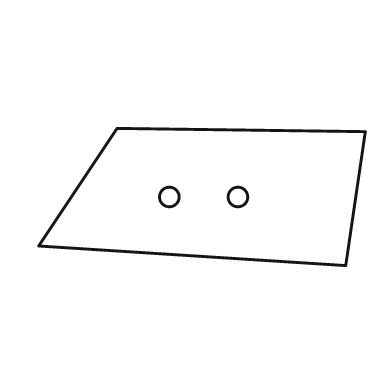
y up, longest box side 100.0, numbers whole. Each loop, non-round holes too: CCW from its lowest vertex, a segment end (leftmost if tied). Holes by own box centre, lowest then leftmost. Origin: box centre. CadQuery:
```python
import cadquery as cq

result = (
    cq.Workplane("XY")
    .moveTo(44.0, -21.0)
    .lineTo(50.0, 20.0)
    .lineTo(-26.0, 21.0)
    .lineTo(-50.0, -15.0)
    .close()
    .moveTo(-10.0, 0.0)
    .circle(3.0)
    .moveTo(11.0, 0.0)
    .circle(3.0)
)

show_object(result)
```